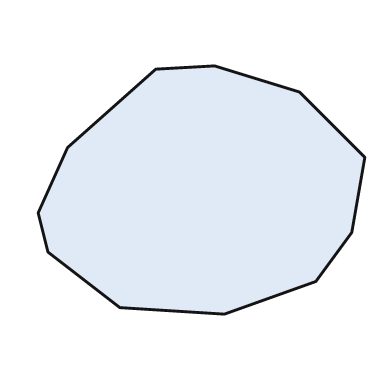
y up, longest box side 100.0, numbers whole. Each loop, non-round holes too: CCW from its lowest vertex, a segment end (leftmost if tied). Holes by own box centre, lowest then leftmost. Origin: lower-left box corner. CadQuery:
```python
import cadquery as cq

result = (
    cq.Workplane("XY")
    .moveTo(57.0, 0.0)
    .lineTo(85.0, 10.0)
    .lineTo(96.0, 25.0)
    .lineTo(100.0, 48.0)
    .lineTo(80.0, 68.0)
    .lineTo(54.0, 76.0)
    .lineTo(36.0, 75.0)
    .lineTo(9.0, 51.0)
    .lineTo(0.0, 31.0)
    .lineTo(3.0, 19.0)
    .lineTo(25.0, 2.0)
    .close()
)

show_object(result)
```